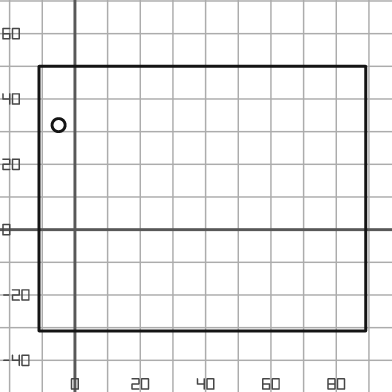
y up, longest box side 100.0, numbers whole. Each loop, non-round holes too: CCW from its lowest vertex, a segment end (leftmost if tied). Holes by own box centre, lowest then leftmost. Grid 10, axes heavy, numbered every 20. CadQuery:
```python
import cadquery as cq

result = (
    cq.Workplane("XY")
    .moveTo(-11.0, -31.0)
    .lineTo(89.0, -31.0)
    .lineTo(89.0, 50.0)
    .lineTo(-11.0, 50.0)
    .close()
    .moveTo(-5.0, 32.0)
    .circle(2.0)
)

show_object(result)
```